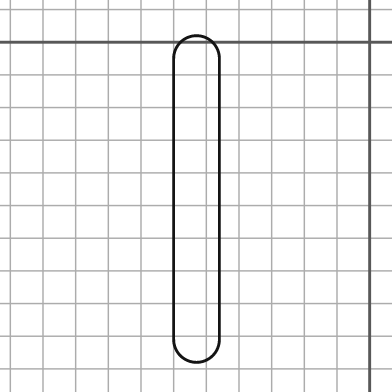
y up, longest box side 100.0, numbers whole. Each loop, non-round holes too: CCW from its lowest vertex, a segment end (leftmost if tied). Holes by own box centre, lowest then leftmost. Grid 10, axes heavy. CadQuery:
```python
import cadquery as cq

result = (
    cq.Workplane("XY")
    .moveTo(-60.0, -91.0)
    .threePointArc((-53.0, -98.0), (-46.0, -91.0))
    .lineTo(-46.0, -5.0)
    .threePointArc((-53.0, 2.0), (-60.0, -5.0))
    .close()
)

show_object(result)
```